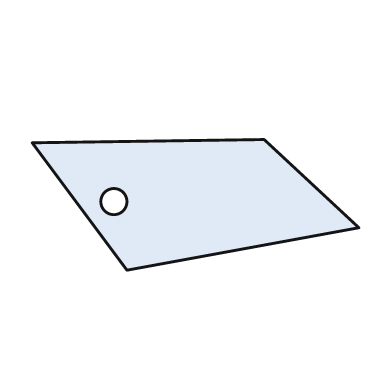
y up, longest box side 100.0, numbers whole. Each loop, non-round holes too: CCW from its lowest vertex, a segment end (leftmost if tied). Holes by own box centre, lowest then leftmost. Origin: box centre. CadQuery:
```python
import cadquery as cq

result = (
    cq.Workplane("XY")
    .moveTo(-21.0, -20.0)
    .lineTo(50.0, -7.0)
    .lineTo(21.0, 20.0)
    .lineTo(-50.0, 19.0)
    .close()
    .moveTo(-25.0, 1.0)
    .circle(4.0)
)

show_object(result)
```